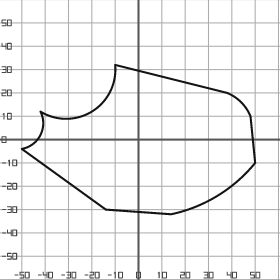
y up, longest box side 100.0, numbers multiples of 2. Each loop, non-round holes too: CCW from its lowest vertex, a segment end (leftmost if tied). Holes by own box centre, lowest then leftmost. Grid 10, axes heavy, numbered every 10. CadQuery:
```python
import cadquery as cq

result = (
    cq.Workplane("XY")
    .moveTo(14.0, -32.0)
    .threePointArc((34.0, -24.0), (50.0, -10.0))
    .lineTo(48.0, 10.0)
    .threePointArc((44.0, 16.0), (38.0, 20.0))
    .lineTo(-10.0, 32.0)
    .threePointArc((-20.0, 12.0), (-42.0, 12.0))
    .threePointArc((-42.0, 2.0), (-50.0, -4.0))
    .lineTo(-14.0, -30.0)
    .close()
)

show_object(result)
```